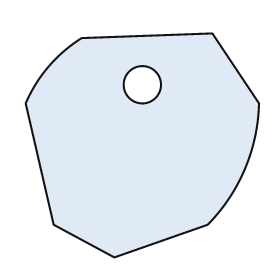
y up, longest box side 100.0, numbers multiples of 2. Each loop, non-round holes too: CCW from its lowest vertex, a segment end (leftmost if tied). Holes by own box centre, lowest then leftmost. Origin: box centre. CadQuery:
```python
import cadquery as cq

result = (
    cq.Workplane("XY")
    .moveTo(-12.0, -48.0)
    .lineTo(28.0, -34.0)
    .threePointArc((44.0, -10.0), (50.0, 18.0))
    .lineTo(30.0, 48.0)
    .lineTo(-26.0, 46.0)
    .threePointArc((-40.0, 34.0), (-50.0, 18.0))
    .lineTo(-38.0, -34.0)
    .close()
    .moveTo(0.0, 26.0)
    .circle(8.0)
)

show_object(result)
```